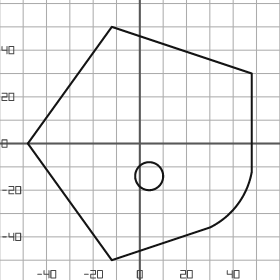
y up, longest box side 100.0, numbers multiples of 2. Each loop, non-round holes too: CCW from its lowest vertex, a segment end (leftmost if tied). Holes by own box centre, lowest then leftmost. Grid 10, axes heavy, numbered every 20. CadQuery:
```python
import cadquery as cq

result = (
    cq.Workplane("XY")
    .moveTo(-12.0, -50.0)
    .lineTo(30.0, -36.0)
    .threePointArc((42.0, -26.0), (48.0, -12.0))
    .lineTo(48.0, 30.0)
    .lineTo(-12.0, 50.0)
    .lineTo(-48.0, 0.0)
    .close()
    .moveTo(4.0, -14.0)
    .circle(6.0)
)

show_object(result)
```